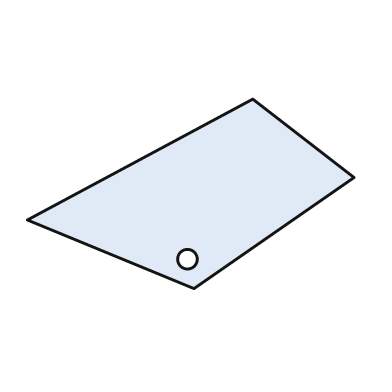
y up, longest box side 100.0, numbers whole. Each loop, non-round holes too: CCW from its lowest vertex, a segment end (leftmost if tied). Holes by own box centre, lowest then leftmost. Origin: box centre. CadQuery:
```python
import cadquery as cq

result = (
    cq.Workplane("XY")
    .moveTo(1.0, -29.0)
    .lineTo(50.0, 5.0)
    .lineTo(19.0, 29.0)
    .lineTo(-50.0, -8.0)
    .close()
    .moveTo(-1.0, -20.0)
    .circle(3.0)
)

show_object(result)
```